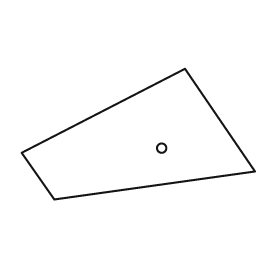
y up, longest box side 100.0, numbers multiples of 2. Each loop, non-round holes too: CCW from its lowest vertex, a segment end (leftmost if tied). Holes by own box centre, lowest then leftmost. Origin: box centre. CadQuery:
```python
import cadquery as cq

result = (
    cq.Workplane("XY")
    .moveTo(-36.0, -28.0)
    .lineTo(50.0, -16.0)
    .lineTo(20.0, 28.0)
    .lineTo(-50.0, -8.0)
    .close()
    .moveTo(10.0, -6.0)
    .circle(2.0)
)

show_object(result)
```